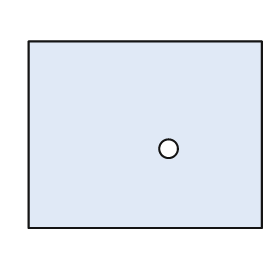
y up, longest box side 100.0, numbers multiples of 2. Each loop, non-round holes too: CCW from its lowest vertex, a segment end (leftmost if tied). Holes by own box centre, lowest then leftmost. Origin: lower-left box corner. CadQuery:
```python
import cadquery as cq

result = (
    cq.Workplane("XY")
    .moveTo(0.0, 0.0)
    .lineTo(100.0, 0.0)
    .lineTo(100.0, 80.0)
    .lineTo(0.0, 80.0)
    .close()
    .moveTo(60.0, 34.0)
    .circle(4.0)
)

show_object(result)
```